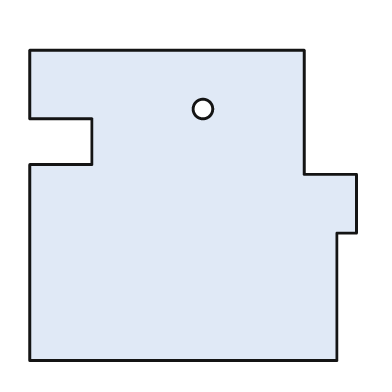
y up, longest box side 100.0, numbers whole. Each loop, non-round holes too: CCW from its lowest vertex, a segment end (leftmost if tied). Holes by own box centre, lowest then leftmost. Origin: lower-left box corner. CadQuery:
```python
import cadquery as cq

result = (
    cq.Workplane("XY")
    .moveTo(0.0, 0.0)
    .lineTo(94.0, 0.0)
    .lineTo(94.0, 39.0)
    .lineTo(100.0, 39.0)
    .lineTo(100.0, 57.0)
    .lineTo(84.0, 57.0)
    .lineTo(84.0, 95.0)
    .lineTo(0.0, 95.0)
    .lineTo(0.0, 74.0)
    .lineTo(19.0, 74.0)
    .lineTo(19.0, 60.0)
    .lineTo(0.0, 60.0)
    .close()
    .moveTo(53.0, 77.0)
    .circle(3.0)
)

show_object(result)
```